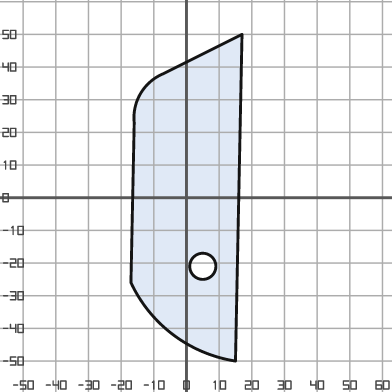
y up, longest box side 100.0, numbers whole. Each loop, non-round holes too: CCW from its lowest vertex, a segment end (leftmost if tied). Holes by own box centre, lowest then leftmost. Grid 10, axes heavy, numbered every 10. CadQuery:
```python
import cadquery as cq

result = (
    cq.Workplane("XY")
    .moveTo(15.0, -50.0)
    .lineTo(17.0, 50.0)
    .lineTo(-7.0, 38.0)
    .threePointArc((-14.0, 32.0), (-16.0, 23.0))
    .lineTo(-17.0, -26.0)
    .threePointArc((-4.0, -42.0), (15.0, -50.0))
    .close()
    .moveTo(5.0, -21.0)
    .circle(4.0)
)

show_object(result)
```